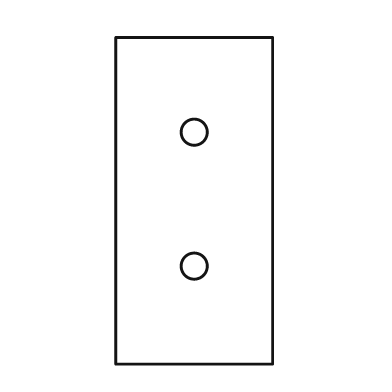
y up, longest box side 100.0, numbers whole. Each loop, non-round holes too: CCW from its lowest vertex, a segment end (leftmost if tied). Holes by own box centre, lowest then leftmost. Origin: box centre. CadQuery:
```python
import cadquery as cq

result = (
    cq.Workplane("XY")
    .moveTo(-24.0, -50.0)
    .lineTo(24.0, -50.0)
    .lineTo(24.0, 50.0)
    .lineTo(-24.0, 50.0)
    .close()
    .moveTo(0.0, -20.0)
    .circle(4.0)
    .moveTo(0.0, 21.0)
    .circle(4.0)
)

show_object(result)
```